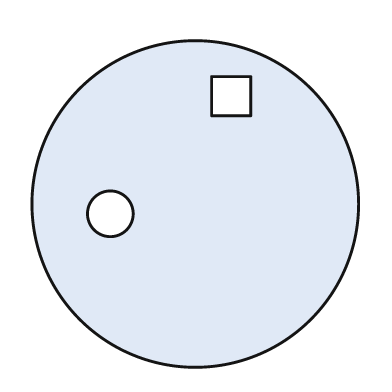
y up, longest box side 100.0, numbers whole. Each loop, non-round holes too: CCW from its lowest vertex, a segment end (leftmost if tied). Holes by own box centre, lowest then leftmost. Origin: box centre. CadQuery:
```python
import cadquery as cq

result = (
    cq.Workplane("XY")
    .moveTo(0.0, 0.0)
    .circle(50.0)
    .moveTo(-26.0, -3.0)
    .circle(7.0)
    .moveTo(5.0, 27.0)
    .lineTo(17.0, 27.0)
    .lineTo(17.0, 39.0)
    .lineTo(5.0, 39.0)
    .close()
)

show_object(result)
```